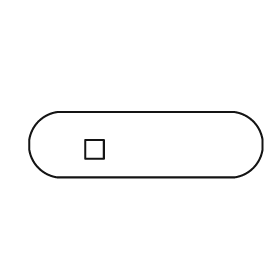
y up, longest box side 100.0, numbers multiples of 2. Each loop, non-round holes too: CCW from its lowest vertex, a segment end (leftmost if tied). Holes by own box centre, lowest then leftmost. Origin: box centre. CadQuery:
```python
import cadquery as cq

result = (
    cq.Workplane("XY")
    .moveTo(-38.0, -14.0)
    .lineTo(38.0, -14.0)
    .threePointArc((46.0, -10.0), (50.0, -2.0))
    .lineTo(50.0, 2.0)
    .threePointArc((46.0, 10.0), (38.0, 14.0))
    .lineTo(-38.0, 14.0)
    .threePointArc((-46.0, 10.0), (-50.0, 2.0))
    .lineTo(-50.0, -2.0)
    .threePointArc((-46.0, -10.0), (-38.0, -14.0))
    .close()
    .moveTo(-26.0, -6.0)
    .lineTo(-18.0, -6.0)
    .lineTo(-18.0, 2.0)
    .lineTo(-26.0, 2.0)
    .close()
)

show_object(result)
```